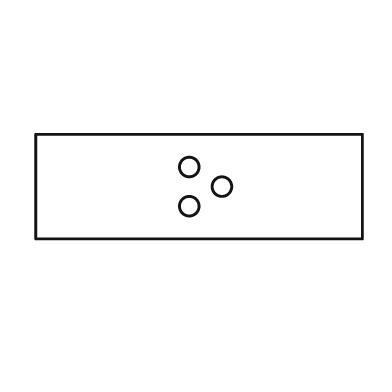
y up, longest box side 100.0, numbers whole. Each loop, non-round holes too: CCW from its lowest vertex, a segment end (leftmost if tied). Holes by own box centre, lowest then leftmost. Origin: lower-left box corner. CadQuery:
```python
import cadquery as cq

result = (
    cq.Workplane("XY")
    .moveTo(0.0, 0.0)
    .lineTo(100.0, 0.0)
    .lineTo(100.0, 32.0)
    .lineTo(0.0, 32.0)
    .close()
    .moveTo(47.0, 10.0)
    .circle(3.0)
    .moveTo(57.0, 16.0)
    .circle(3.0)
    .moveTo(47.0, 22.0)
    .circle(3.0)
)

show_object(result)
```